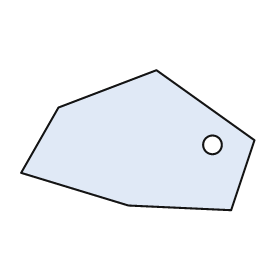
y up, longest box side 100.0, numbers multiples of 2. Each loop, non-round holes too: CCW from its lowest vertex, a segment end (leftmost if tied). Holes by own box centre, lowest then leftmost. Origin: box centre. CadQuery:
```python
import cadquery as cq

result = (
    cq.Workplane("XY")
    .moveTo(40.0, -30.0)
    .lineTo(50.0, 0.0)
    .lineTo(8.0, 30.0)
    .lineTo(-34.0, 14.0)
    .lineTo(-50.0, -14.0)
    .lineTo(-4.0, -28.0)
    .close()
    .moveTo(32.0, -2.0)
    .circle(4.0)
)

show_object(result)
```